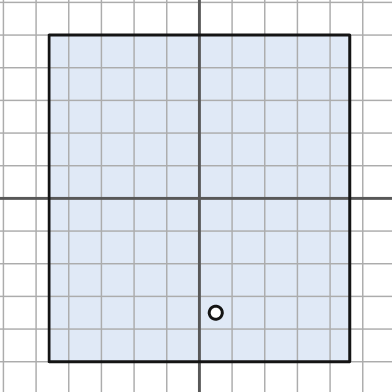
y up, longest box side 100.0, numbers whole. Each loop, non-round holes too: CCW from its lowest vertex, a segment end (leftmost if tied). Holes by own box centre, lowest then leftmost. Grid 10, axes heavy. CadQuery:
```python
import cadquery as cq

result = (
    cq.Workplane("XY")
    .moveTo(-46.0, -50.0)
    .lineTo(46.0, -50.0)
    .lineTo(46.0, 50.0)
    .lineTo(-46.0, 50.0)
    .close()
    .moveTo(5.0, -35.0)
    .circle(2.0)
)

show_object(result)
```